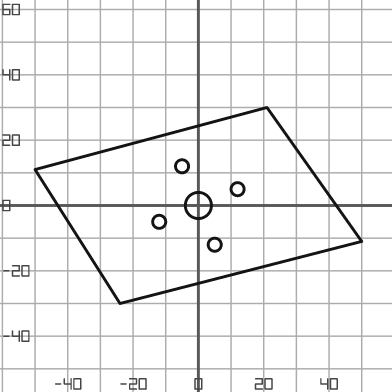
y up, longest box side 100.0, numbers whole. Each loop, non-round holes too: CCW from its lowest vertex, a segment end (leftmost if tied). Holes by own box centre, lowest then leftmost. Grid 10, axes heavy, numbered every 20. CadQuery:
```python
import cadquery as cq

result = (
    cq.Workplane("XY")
    .moveTo(-24.0, -30.0)
    .lineTo(50.0, -11.0)
    .lineTo(21.0, 30.0)
    .lineTo(-50.0, 11.0)
    .close()
    .moveTo(5.0, -12.0)
    .circle(2.0)
    .moveTo(-12.0, -5.0)
    .circle(2.0)
    .moveTo(0.0, 0.0)
    .circle(4.0)
    .moveTo(12.0, 5.0)
    .circle(2.0)
    .moveTo(-5.0, 12.0)
    .circle(2.0)
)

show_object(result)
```